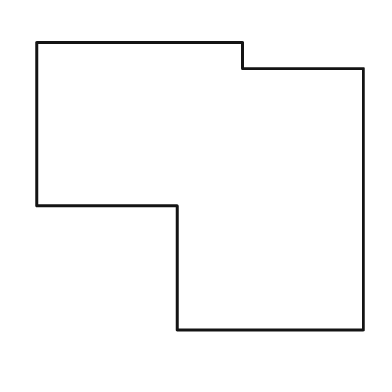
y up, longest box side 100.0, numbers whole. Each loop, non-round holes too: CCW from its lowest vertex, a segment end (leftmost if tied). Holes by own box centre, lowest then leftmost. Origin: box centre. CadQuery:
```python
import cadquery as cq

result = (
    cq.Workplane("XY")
    .moveTo(-7.0, -44.0)
    .lineTo(50.0, -44.0)
    .lineTo(50.0, 36.0)
    .lineTo(13.0, 36.0)
    .lineTo(13.0, 44.0)
    .lineTo(-50.0, 44.0)
    .lineTo(-50.0, -6.0)
    .lineTo(-7.0, -6.0)
    .close()
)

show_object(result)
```